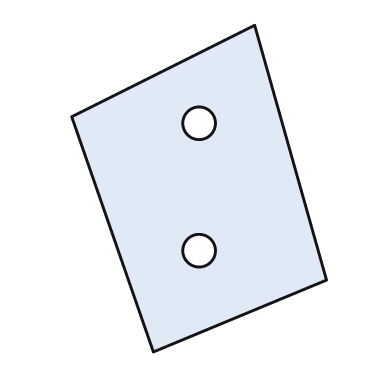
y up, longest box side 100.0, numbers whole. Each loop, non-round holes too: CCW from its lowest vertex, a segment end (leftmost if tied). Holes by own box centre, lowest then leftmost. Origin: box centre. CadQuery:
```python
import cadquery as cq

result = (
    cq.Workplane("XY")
    .moveTo(-14.0, -50.0)
    .lineTo(39.0, -28.0)
    .lineTo(17.0, 50.0)
    .lineTo(-39.0, 22.0)
    .close()
    .moveTo(0.0, -19.0)
    .circle(5.0)
    .moveTo(0.0, 20.0)
    .circle(5.0)
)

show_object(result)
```